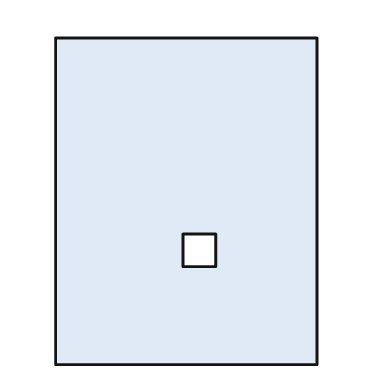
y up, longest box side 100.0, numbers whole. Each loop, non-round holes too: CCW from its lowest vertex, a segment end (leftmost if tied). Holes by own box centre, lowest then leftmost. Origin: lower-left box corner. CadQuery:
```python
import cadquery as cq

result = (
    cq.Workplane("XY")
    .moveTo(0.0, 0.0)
    .lineTo(80.0, 0.0)
    .lineTo(80.0, 100.0)
    .lineTo(0.0, 100.0)
    .close()
    .moveTo(39.0, 30.0)
    .lineTo(49.0, 30.0)
    .lineTo(49.0, 40.0)
    .lineTo(39.0, 40.0)
    .close()
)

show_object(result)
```